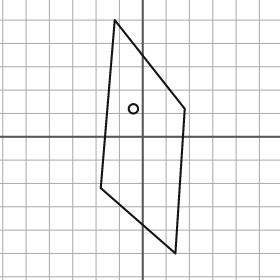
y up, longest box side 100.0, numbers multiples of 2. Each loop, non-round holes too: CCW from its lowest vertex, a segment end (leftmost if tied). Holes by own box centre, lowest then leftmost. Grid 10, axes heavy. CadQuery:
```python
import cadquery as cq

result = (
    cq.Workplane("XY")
    .moveTo(14.0, -50.0)
    .lineTo(18.0, 12.0)
    .lineTo(-12.0, 50.0)
    .lineTo(-18.0, -22.0)
    .close()
    .moveTo(-4.0, 12.0)
    .circle(2.0)
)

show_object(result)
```